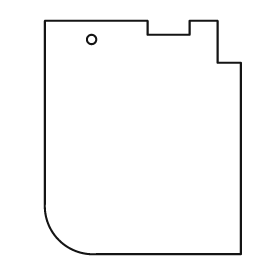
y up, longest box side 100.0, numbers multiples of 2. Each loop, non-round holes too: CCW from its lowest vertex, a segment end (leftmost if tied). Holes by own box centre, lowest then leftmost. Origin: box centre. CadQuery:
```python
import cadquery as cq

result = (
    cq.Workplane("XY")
    .moveTo(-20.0, -50.0)
    .lineTo(42.0, -50.0)
    .lineTo(42.0, 32.0)
    .lineTo(32.0, 32.0)
    .lineTo(32.0, 50.0)
    .lineTo(20.0, 50.0)
    .lineTo(20.0, 44.0)
    .lineTo(2.0, 44.0)
    .lineTo(2.0, 50.0)
    .lineTo(-42.0, 50.0)
    .lineTo(-42.0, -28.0)
    .threePointArc((-36.0, -44.0), (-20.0, -50.0))
    .close()
    .moveTo(-22.0, 42.0)
    .circle(2.0)
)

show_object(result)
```